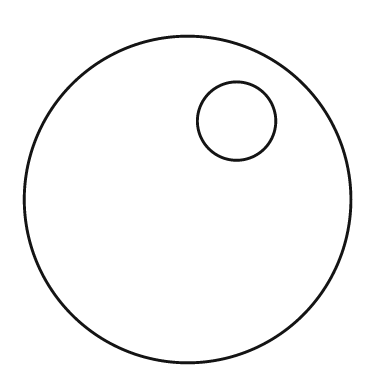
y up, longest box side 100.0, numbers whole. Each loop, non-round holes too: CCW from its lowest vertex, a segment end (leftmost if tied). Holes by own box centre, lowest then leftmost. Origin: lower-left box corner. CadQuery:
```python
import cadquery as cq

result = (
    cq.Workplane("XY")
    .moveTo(50.0, 50.0)
    .circle(50.0)
    .moveTo(65.0, 74.0)
    .circle(12.0)
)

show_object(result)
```